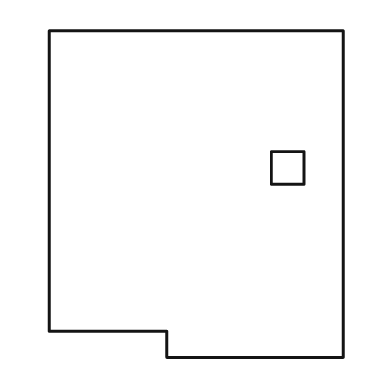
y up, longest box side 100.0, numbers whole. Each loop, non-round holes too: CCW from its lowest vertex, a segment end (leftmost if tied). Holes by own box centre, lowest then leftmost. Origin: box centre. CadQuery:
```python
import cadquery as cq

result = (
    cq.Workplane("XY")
    .moveTo(-9.0, -50.0)
    .lineTo(45.0, -50.0)
    .lineTo(45.0, 50.0)
    .lineTo(-45.0, 50.0)
    .lineTo(-45.0, -42.0)
    .lineTo(-9.0, -42.0)
    .close()
    .moveTo(23.0, 3.0)
    .lineTo(33.0, 3.0)
    .lineTo(33.0, 13.0)
    .lineTo(23.0, 13.0)
    .close()
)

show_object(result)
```